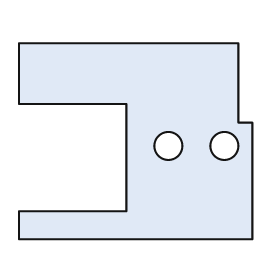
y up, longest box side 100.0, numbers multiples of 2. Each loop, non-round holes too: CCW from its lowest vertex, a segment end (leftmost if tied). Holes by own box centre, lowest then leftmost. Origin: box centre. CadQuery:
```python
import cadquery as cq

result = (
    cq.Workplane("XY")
    .moveTo(-50.0, -42.0)
    .lineTo(50.0, -42.0)
    .lineTo(50.0, 8.0)
    .lineTo(44.0, 8.0)
    .lineTo(44.0, 42.0)
    .lineTo(-50.0, 42.0)
    .lineTo(-50.0, 16.0)
    .lineTo(-4.0, 16.0)
    .lineTo(-4.0, -30.0)
    .lineTo(-50.0, -30.0)
    .close()
    .moveTo(14.0, -2.0)
    .circle(6.0)
    .moveTo(38.0, -2.0)
    .circle(6.0)
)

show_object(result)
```